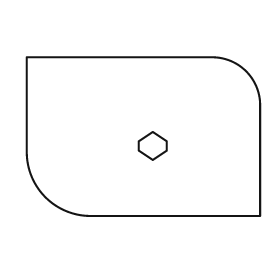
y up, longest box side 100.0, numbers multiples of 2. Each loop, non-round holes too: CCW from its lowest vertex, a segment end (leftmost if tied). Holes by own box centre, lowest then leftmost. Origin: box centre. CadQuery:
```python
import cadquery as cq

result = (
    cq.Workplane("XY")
    .moveTo(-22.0, -34.0)
    .lineTo(50.0, -34.0)
    .lineTo(50.0, 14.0)
    .threePointArc((44.0, 28.0), (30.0, 34.0))
    .lineTo(-50.0, 34.0)
    .lineTo(-50.0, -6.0)
    .threePointArc((-42.0, -26.0), (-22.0, -34.0))
    .close()
    .moveTo(4.0, -10.0)
    .lineTo(10.0, -6.0)
    .lineTo(10.0, -2.0)
    .lineTo(4.0, 2.0)
    .lineTo(-2.0, -2.0)
    .lineTo(-2.0, -6.0)
    .close()
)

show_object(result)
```